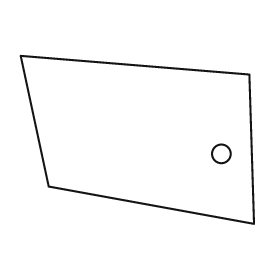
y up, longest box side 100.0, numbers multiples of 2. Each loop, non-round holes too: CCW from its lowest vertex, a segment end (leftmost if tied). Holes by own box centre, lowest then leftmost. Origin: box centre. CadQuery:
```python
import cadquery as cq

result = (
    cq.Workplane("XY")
    .moveTo(50.0, -36.0)
    .lineTo(48.0, 28.0)
    .lineTo(-50.0, 36.0)
    .lineTo(-38.0, -20.0)
    .close()
    .moveTo(36.0, -6.0)
    .circle(4.0)
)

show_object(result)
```